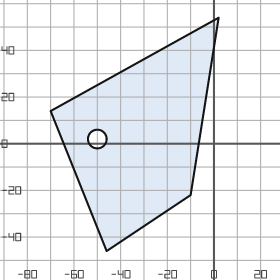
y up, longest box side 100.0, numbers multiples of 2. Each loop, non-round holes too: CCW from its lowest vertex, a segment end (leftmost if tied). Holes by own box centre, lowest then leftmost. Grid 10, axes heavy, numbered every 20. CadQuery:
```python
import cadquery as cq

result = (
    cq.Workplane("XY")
    .moveTo(-46.0, -46.0)
    .lineTo(-10.0, -22.0)
    .lineTo(2.0, 54.0)
    .lineTo(-70.0, 14.0)
    .close()
    .moveTo(-50.0, 2.0)
    .circle(4.0)
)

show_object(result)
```